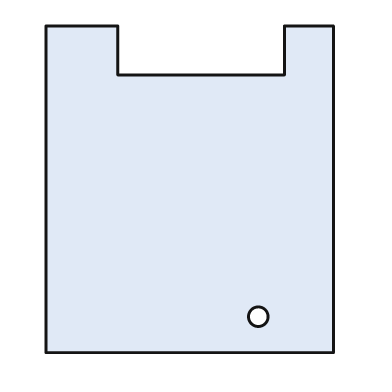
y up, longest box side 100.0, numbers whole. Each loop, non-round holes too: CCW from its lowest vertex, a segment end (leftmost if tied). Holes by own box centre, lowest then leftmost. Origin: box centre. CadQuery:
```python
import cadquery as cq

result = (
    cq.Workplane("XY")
    .moveTo(-44.0, -50.0)
    .lineTo(44.0, -50.0)
    .lineTo(44.0, 50.0)
    .lineTo(29.0, 50.0)
    .lineTo(29.0, 35.0)
    .lineTo(-22.0, 35.0)
    .lineTo(-22.0, 50.0)
    .lineTo(-44.0, 50.0)
    .close()
    .moveTo(21.0, -39.0)
    .circle(3.0)
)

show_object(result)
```